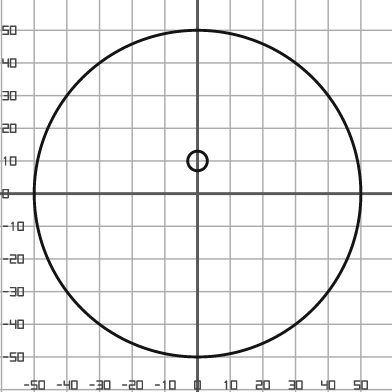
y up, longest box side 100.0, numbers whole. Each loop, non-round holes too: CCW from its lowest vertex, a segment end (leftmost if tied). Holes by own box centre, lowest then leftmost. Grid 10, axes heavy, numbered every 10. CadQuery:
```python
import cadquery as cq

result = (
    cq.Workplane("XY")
    .moveTo(0.0, 0.0)
    .circle(50.0)
    .moveTo(0.0, 10.0)
    .circle(3.0)
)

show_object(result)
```